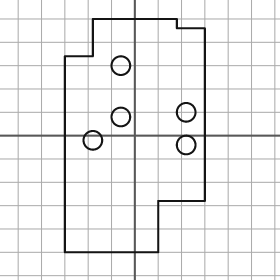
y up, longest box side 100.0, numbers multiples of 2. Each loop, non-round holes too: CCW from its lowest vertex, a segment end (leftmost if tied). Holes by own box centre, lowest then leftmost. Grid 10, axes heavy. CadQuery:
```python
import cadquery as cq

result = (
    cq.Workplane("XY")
    .moveTo(-30.0, -50.0)
    .lineTo(10.0, -50.0)
    .lineTo(10.0, -28.0)
    .lineTo(30.0, -28.0)
    .lineTo(30.0, 46.0)
    .lineTo(18.0, 46.0)
    .lineTo(18.0, 50.0)
    .lineTo(-18.0, 50.0)
    .lineTo(-18.0, 34.0)
    .lineTo(-30.0, 34.0)
    .close()
    .moveTo(22.0, -4.0)
    .circle(4.0)
    .moveTo(-18.0, -2.0)
    .circle(4.0)
    .moveTo(-6.0, 8.0)
    .circle(4.0)
    .moveTo(22.0, 10.0)
    .circle(4.0)
    .moveTo(-6.0, 30.0)
    .circle(4.0)
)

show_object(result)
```